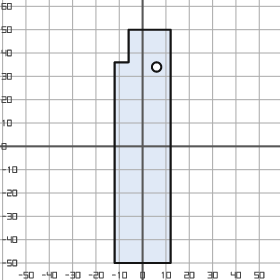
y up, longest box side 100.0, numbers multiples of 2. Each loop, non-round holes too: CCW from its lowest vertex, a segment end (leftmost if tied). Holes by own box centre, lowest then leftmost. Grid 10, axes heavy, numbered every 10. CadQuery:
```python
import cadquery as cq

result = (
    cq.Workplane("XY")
    .moveTo(-12.0, -50.0)
    .lineTo(12.0, -50.0)
    .lineTo(12.0, 50.0)
    .lineTo(-6.0, 50.0)
    .lineTo(-6.0, 36.0)
    .lineTo(-12.0, 36.0)
    .close()
    .moveTo(6.0, 34.0)
    .circle(2.0)
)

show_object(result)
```